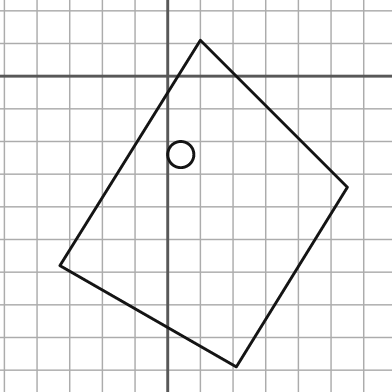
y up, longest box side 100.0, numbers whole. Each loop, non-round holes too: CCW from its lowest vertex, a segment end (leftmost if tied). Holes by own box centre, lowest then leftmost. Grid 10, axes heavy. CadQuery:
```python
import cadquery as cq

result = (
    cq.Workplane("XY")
    .moveTo(21.0, -89.0)
    .lineTo(55.0, -34.0)
    .lineTo(10.0, 11.0)
    .lineTo(-33.0, -58.0)
    .close()
    .moveTo(4.0, -24.0)
    .circle(4.0)
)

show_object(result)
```